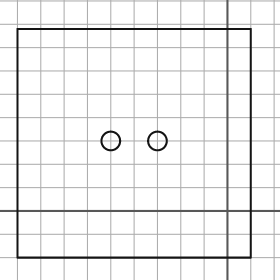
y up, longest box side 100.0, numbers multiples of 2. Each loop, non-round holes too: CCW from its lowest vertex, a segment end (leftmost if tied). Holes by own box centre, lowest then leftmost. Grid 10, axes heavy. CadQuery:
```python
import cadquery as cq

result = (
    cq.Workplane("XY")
    .moveTo(-90.0, -20.0)
    .lineTo(10.0, -20.0)
    .lineTo(10.0, 78.0)
    .lineTo(-90.0, 78.0)
    .close()
    .moveTo(-50.0, 30.0)
    .circle(4.0)
    .moveTo(-30.0, 30.0)
    .circle(4.0)
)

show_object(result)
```